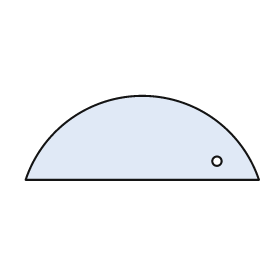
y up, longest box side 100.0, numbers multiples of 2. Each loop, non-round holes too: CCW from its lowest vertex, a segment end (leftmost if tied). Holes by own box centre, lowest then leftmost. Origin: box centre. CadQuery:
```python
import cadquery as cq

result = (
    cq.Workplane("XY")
    .moveTo(-50.0, -18.0)
    .lineTo(50.0, -18.0)
    .threePointArc((0.0, 18.0), (-50.0, -18.0))
    .close()
    .moveTo(32.0, -10.0)
    .circle(2.0)
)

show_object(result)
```